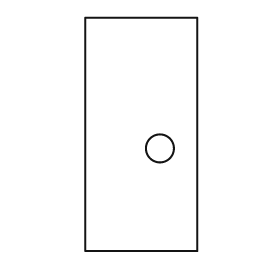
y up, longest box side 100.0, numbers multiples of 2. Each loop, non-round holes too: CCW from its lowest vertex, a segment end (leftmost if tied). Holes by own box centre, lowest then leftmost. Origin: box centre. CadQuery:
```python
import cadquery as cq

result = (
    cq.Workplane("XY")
    .moveTo(-24.0, -50.0)
    .lineTo(24.0, -50.0)
    .lineTo(24.0, 50.0)
    .lineTo(-24.0, 50.0)
    .close()
    .moveTo(8.0, -6.0)
    .circle(6.0)
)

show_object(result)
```